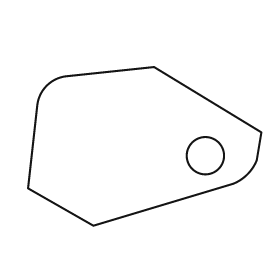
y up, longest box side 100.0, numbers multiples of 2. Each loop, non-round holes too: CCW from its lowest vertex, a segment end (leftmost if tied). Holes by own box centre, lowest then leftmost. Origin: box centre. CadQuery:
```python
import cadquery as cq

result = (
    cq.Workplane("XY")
    .moveTo(-22.0, -34.0)
    .lineTo(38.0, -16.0)
    .threePointArc((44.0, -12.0), (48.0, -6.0))
    .lineTo(50.0, 6.0)
    .lineTo(4.0, 34.0)
    .lineTo(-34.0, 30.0)
    .threePointArc((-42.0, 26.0), (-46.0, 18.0))
    .lineTo(-50.0, -18.0)
    .close()
    .moveTo(26.0, -4.0)
    .circle(8.0)
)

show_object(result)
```